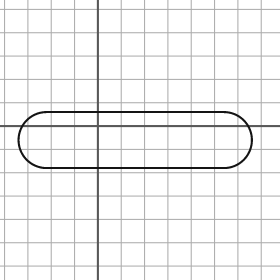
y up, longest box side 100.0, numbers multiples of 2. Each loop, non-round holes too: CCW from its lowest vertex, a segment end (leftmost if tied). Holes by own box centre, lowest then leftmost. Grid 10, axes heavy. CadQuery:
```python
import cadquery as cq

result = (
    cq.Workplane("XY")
    .moveTo(-22.0, -18.0)
    .lineTo(54.0, -18.0)
    .threePointArc((66.0, -6.0), (54.0, 6.0))
    .lineTo(-22.0, 6.0)
    .threePointArc((-34.0, -6.0), (-22.0, -18.0))
    .close()
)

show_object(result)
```